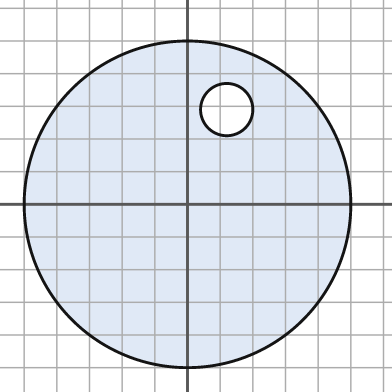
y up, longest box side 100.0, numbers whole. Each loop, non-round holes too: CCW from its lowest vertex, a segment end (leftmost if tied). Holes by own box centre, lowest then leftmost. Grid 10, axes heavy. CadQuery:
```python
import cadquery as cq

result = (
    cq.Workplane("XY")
    .moveTo(0.0, 0.0)
    .circle(50.0)
    .moveTo(12.0, 29.0)
    .circle(8.0)
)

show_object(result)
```